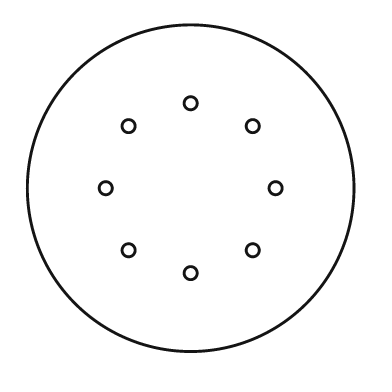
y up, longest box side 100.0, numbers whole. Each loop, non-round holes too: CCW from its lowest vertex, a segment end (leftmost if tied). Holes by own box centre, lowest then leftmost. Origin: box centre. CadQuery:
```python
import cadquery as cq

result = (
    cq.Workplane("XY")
    .moveTo(0.0, 0.0)
    .circle(50.0)
    .moveTo(0.0, -26.0)
    .circle(2.0)
    .moveTo(-19.0, -19.0)
    .circle(2.0)
    .moveTo(19.0, -19.0)
    .circle(2.0)
    .moveTo(-26.0, 0.0)
    .circle(2.0)
    .moveTo(26.0, 0.0)
    .circle(2.0)
    .moveTo(-19.0, 19.0)
    .circle(2.0)
    .moveTo(19.0, 19.0)
    .circle(2.0)
    .moveTo(0.0, 26.0)
    .circle(2.0)
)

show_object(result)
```